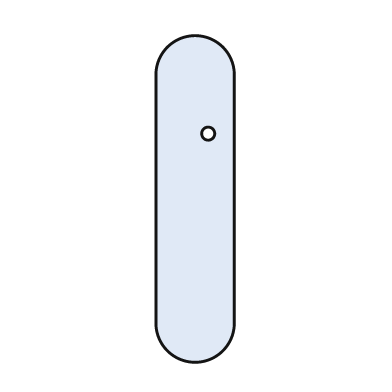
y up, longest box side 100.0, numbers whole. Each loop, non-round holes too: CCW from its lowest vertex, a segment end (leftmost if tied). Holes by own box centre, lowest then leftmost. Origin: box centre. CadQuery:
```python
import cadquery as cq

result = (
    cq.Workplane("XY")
    .moveTo(-12.0, -38.0)
    .threePointArc((0.0, -50.0), (12.0, -38.0))
    .lineTo(12.0, 38.0)
    .threePointArc((0.0, 50.0), (-12.0, 38.0))
    .close()
    .moveTo(4.0, 20.0)
    .circle(2.0)
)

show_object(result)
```